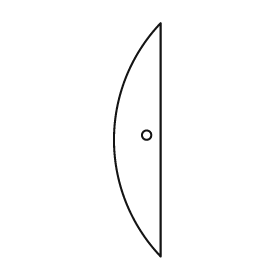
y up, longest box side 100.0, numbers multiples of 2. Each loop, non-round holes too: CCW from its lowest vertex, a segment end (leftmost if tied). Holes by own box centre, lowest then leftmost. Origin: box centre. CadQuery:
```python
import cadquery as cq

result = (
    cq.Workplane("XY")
    .moveTo(10.0, -50.0)
    .lineTo(10.0, 50.0)
    .threePointArc((-10.0, 0.0), (10.0, -50.0))
    .close()
    .moveTo(4.0, 2.0)
    .circle(2.0)
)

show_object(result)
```